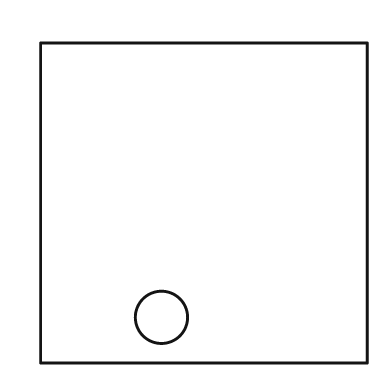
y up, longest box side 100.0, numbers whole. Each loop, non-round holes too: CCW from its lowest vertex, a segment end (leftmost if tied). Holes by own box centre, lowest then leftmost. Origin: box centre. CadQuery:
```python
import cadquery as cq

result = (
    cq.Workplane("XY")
    .moveTo(-50.0, -49.0)
    .lineTo(50.0, -49.0)
    .lineTo(50.0, 49.0)
    .lineTo(-50.0, 49.0)
    .close()
    .moveTo(-13.0, -35.0)
    .circle(8.0)
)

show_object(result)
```